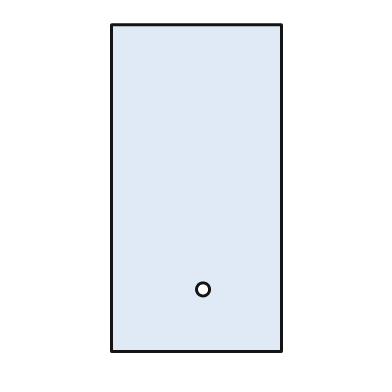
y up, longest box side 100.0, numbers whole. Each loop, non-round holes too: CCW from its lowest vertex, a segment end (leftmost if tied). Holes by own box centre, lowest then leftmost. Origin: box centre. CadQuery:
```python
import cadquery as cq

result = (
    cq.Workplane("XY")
    .moveTo(-26.0, -50.0)
    .lineTo(26.0, -50.0)
    .lineTo(26.0, 50.0)
    .lineTo(-26.0, 50.0)
    .close()
    .moveTo(2.0, -31.0)
    .circle(2.0)
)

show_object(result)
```